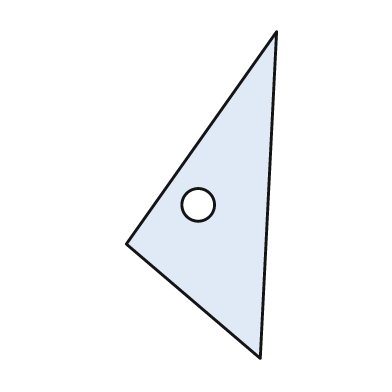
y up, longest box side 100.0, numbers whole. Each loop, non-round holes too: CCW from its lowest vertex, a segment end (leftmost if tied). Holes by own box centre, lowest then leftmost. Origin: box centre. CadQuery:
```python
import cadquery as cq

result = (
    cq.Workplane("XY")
    .moveTo(18.0, -50.0)
    .lineTo(23.0, 50.0)
    .lineTo(-23.0, -15.0)
    .close()
    .moveTo(-1.0, -3.0)
    .circle(5.0)
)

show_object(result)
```